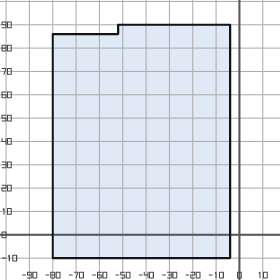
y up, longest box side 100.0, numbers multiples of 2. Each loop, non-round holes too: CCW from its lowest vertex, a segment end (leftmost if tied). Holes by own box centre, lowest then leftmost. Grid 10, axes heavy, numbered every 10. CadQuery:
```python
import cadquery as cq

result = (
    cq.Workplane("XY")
    .moveTo(-80.0, -10.0)
    .lineTo(-4.0, -10.0)
    .lineTo(-4.0, 90.0)
    .lineTo(-52.0, 90.0)
    .lineTo(-52.0, 86.0)
    .lineTo(-80.0, 86.0)
    .close()
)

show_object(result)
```